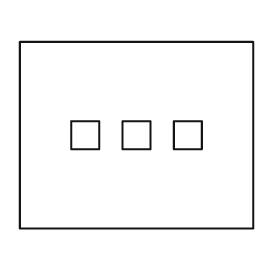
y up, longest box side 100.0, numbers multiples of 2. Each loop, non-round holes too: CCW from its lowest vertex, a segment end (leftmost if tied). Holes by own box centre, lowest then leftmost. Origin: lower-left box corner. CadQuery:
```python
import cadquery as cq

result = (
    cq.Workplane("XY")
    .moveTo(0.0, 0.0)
    .lineTo(100.0, 0.0)
    .lineTo(100.0, 80.0)
    .lineTo(0.0, 80.0)
    .close()
    .moveTo(22.0, 34.0)
    .lineTo(34.0, 34.0)
    .lineTo(34.0, 46.0)
    .lineTo(22.0, 46.0)
    .close()
    .moveTo(44.0, 34.0)
    .lineTo(56.0, 34.0)
    .lineTo(56.0, 46.0)
    .lineTo(44.0, 46.0)
    .close()
    .moveTo(66.0, 34.0)
    .lineTo(78.0, 34.0)
    .lineTo(78.0, 46.0)
    .lineTo(66.0, 46.0)
    .close()
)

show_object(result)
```